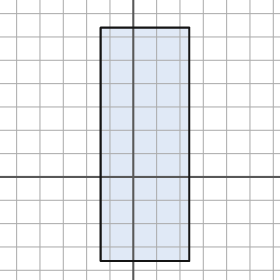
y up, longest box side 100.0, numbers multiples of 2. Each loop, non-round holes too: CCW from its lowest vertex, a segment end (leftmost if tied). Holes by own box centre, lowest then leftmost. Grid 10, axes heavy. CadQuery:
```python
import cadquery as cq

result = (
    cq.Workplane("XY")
    .moveTo(-14.0, -36.0)
    .lineTo(24.0, -36.0)
    .lineTo(24.0, 64.0)
    .lineTo(-14.0, 64.0)
    .close()
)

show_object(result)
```